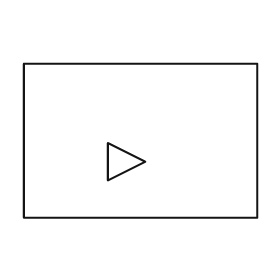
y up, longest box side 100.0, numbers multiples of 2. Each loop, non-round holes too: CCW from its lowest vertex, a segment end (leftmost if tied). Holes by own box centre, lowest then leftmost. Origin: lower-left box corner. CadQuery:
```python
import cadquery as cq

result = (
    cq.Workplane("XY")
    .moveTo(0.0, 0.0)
    .lineTo(100.0, 0.0)
    .lineTo(100.0, 66.0)
    .lineTo(0.0, 66.0)
    .close()
    .moveTo(36.0, 16.0)
    .lineTo(52.0, 24.0)
    .lineTo(36.0, 32.0)
    .close()
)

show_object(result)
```